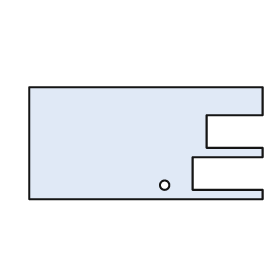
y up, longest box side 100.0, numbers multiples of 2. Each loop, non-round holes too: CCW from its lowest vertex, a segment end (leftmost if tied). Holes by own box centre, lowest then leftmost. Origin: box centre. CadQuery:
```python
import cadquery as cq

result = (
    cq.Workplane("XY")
    .moveTo(-50.0, -24.0)
    .lineTo(50.0, -24.0)
    .lineTo(50.0, -20.0)
    .lineTo(20.0, -20.0)
    .lineTo(20.0, -6.0)
    .lineTo(50.0, -6.0)
    .lineTo(50.0, -2.0)
    .lineTo(26.0, -2.0)
    .lineTo(26.0, 12.0)
    .lineTo(50.0, 12.0)
    .lineTo(50.0, 24.0)
    .lineTo(-50.0, 24.0)
    .close()
    .moveTo(8.0, -18.0)
    .circle(2.0)
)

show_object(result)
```